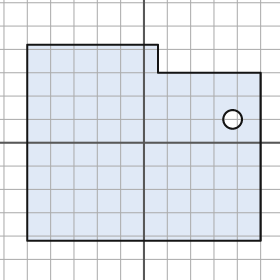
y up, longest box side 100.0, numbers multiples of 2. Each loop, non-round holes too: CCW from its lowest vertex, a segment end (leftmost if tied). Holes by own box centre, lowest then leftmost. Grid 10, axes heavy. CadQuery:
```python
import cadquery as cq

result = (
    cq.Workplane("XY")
    .moveTo(-50.0, -42.0)
    .lineTo(50.0, -42.0)
    .lineTo(50.0, 30.0)
    .lineTo(6.0, 30.0)
    .lineTo(6.0, 42.0)
    .lineTo(-50.0, 42.0)
    .close()
    .moveTo(38.0, 10.0)
    .circle(4.0)
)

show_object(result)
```